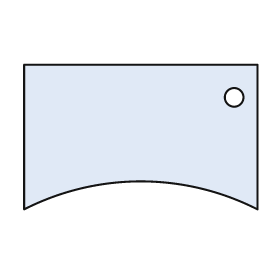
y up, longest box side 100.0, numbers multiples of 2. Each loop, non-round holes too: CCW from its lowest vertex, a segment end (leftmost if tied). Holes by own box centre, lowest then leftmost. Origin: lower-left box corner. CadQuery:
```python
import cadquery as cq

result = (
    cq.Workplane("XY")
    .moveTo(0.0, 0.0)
    .threePointArc((50.0, 12.0), (100.0, 0.0))
    .lineTo(100.0, 62.0)
    .lineTo(0.0, 62.0)
    .close()
    .moveTo(90.0, 48.0)
    .circle(4.0)
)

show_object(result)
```